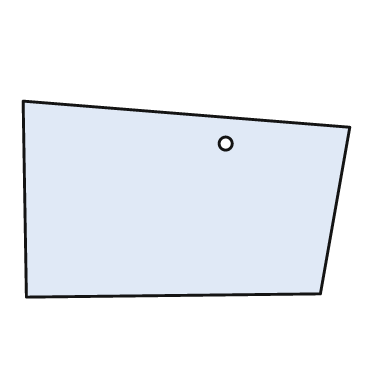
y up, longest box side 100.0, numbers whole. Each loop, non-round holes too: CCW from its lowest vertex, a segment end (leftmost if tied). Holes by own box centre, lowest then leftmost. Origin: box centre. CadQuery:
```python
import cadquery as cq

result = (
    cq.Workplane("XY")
    .moveTo(-49.0, -30.0)
    .lineTo(41.0, -29.0)
    .lineTo(50.0, 22.0)
    .lineTo(-50.0, 30.0)
    .close()
    .moveTo(12.0, 17.0)
    .circle(2.0)
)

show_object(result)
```